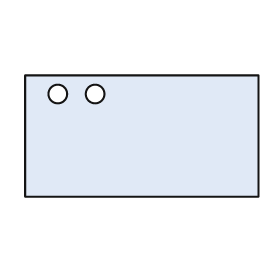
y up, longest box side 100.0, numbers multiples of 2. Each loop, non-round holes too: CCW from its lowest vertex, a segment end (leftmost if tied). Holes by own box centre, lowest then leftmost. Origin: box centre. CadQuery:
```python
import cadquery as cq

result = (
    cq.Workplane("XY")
    .moveTo(-50.0, -26.0)
    .lineTo(50.0, -26.0)
    .lineTo(50.0, 26.0)
    .lineTo(-50.0, 26.0)
    .close()
    .moveTo(-36.0, 18.0)
    .circle(4.0)
    .moveTo(-20.0, 18.0)
    .circle(4.0)
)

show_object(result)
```